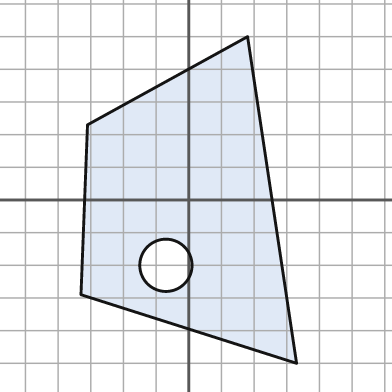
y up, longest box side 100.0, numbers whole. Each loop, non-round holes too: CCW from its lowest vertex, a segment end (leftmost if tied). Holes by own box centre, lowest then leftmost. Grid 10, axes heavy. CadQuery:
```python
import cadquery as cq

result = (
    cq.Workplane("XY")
    .moveTo(33.0, -50.0)
    .lineTo(18.0, 50.0)
    .lineTo(-31.0, 23.0)
    .lineTo(-33.0, -29.0)
    .close()
    .moveTo(-7.0, -20.0)
    .circle(8.0)
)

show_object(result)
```